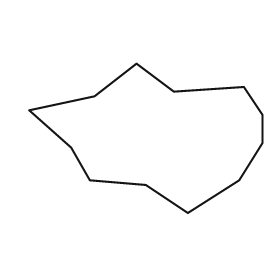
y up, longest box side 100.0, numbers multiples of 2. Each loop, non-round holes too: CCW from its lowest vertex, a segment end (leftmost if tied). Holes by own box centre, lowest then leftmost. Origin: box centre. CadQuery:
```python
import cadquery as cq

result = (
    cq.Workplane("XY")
    .moveTo(18.0, -32.0)
    .lineTo(40.0, -18.0)
    .lineTo(50.0, -2.0)
    .lineTo(50.0, 10.0)
    .lineTo(42.0, 22.0)
    .lineTo(12.0, 20.0)
    .lineTo(-4.0, 32.0)
    .lineTo(-22.0, 18.0)
    .lineTo(-50.0, 12.0)
    .lineTo(-32.0, -4.0)
    .lineTo(-24.0, -18.0)
    .lineTo(0.0, -20.0)
    .close()
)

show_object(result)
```